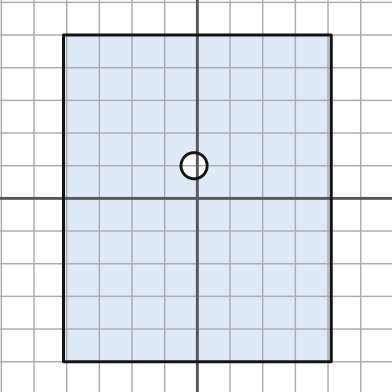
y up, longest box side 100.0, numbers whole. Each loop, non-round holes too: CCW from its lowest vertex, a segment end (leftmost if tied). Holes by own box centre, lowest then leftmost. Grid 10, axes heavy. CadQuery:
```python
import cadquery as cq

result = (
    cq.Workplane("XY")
    .moveTo(-41.0, -50.0)
    .lineTo(41.0, -50.0)
    .lineTo(41.0, 50.0)
    .lineTo(-41.0, 50.0)
    .close()
    .moveTo(-1.0, 10.0)
    .circle(4.0)
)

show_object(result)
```